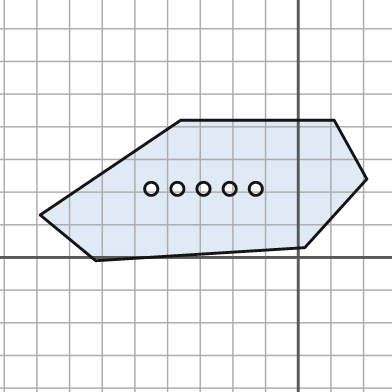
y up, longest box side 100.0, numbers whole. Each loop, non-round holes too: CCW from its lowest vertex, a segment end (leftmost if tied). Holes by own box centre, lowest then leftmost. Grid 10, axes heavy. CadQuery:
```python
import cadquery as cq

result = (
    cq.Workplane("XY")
    .moveTo(-62.0, -1.0)
    .lineTo(2.0, 3.0)
    .lineTo(21.0, 24.0)
    .lineTo(11.0, 42.0)
    .lineTo(-36.0, 42.0)
    .lineTo(-79.0, 13.0)
    .close()
    .moveTo(-45.0, 21.0)
    .circle(2.0)
    .moveTo(-37.0, 21.0)
    .circle(2.0)
    .moveTo(-29.0, 21.0)
    .circle(2.0)
    .moveTo(-21.0, 21.0)
    .circle(2.0)
    .moveTo(-13.0, 21.0)
    .circle(2.0)
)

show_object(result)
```